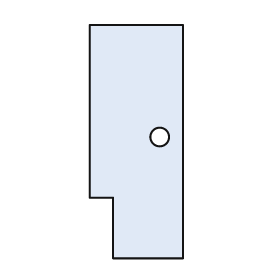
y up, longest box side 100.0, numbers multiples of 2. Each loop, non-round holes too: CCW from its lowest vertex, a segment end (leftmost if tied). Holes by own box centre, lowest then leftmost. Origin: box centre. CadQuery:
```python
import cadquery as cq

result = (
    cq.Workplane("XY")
    .moveTo(-10.0, -50.0)
    .lineTo(20.0, -50.0)
    .lineTo(20.0, 50.0)
    .lineTo(-20.0, 50.0)
    .lineTo(-20.0, -24.0)
    .lineTo(-10.0, -24.0)
    .close()
    .moveTo(10.0, 2.0)
    .circle(4.0)
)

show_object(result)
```